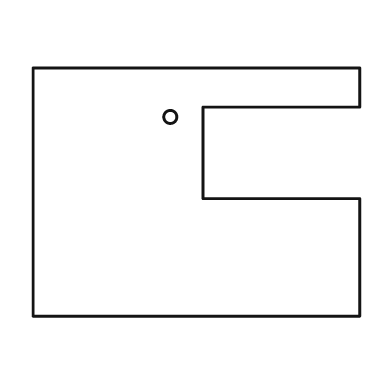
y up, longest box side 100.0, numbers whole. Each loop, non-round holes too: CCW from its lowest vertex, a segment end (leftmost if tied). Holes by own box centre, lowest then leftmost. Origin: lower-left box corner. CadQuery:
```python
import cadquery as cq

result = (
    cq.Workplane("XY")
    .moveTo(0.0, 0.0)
    .lineTo(100.0, 0.0)
    .lineTo(100.0, 36.0)
    .lineTo(52.0, 36.0)
    .lineTo(52.0, 64.0)
    .lineTo(100.0, 64.0)
    .lineTo(100.0, 76.0)
    .lineTo(0.0, 76.0)
    .close()
    .moveTo(42.0, 61.0)
    .circle(2.0)
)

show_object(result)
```